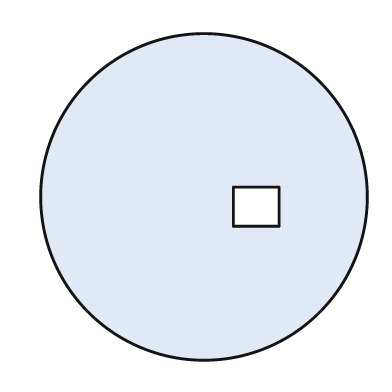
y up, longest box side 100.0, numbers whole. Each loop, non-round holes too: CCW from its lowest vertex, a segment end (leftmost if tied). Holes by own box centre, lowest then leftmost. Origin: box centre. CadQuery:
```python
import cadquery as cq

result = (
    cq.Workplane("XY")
    .moveTo(0.0, 0.0)
    .circle(50.0)
    .moveTo(9.0, -9.0)
    .lineTo(23.0, -9.0)
    .lineTo(23.0, 3.0)
    .lineTo(9.0, 3.0)
    .close()
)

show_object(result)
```